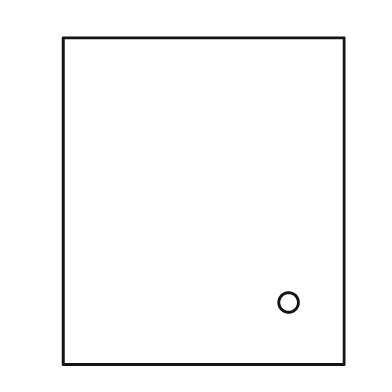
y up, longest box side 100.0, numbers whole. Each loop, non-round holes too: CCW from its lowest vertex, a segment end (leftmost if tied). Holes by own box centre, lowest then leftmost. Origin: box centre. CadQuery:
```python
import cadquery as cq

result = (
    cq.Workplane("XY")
    .moveTo(-43.0, -50.0)
    .lineTo(43.0, -50.0)
    .lineTo(43.0, 50.0)
    .lineTo(-43.0, 50.0)
    .close()
    .moveTo(26.0, -31.0)
    .circle(3.0)
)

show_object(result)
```